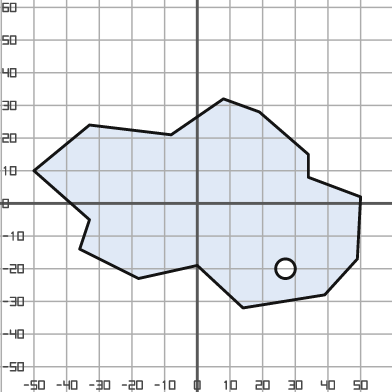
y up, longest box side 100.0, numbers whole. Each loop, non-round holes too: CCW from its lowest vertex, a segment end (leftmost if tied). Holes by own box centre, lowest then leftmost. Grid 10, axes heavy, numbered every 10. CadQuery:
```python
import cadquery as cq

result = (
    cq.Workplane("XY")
    .moveTo(14.0, -32.0)
    .lineTo(39.0, -28.0)
    .lineTo(49.0, -17.0)
    .lineTo(50.0, 2.0)
    .lineTo(34.0, 8.0)
    .lineTo(34.0, 15.0)
    .lineTo(19.0, 28.0)
    .lineTo(8.0, 32.0)
    .lineTo(-8.0, 21.0)
    .lineTo(-33.0, 24.0)
    .lineTo(-50.0, 10.0)
    .lineTo(-33.0, -5.0)
    .lineTo(-36.0, -14.0)
    .lineTo(-18.0, -23.0)
    .lineTo(0.0, -19.0)
    .close()
    .moveTo(27.0, -20.0)
    .circle(3.0)
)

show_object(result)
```